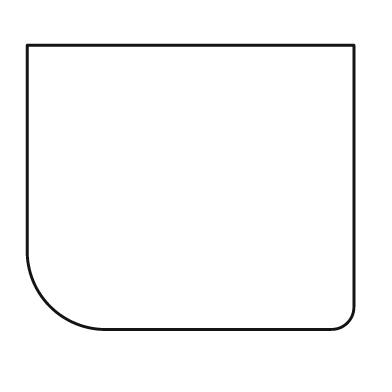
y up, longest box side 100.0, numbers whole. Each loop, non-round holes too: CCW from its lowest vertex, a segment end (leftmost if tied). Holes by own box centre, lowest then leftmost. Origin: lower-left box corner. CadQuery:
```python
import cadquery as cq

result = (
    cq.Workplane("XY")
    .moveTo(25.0, 0.0)
    .lineTo(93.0, 0.0)
    .threePointArc((98.0, 2.0), (100.0, 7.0))
    .lineTo(100.0, 87.0)
    .lineTo(0.0, 87.0)
    .lineTo(0.0, 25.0)
    .threePointArc((7.0, 7.0), (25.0, 0.0))
    .close()
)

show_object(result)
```